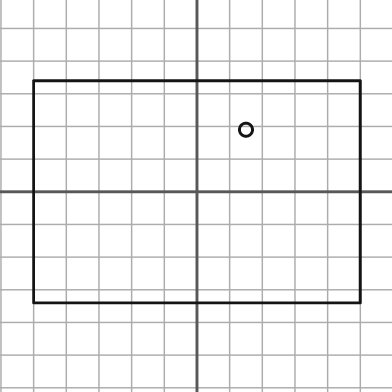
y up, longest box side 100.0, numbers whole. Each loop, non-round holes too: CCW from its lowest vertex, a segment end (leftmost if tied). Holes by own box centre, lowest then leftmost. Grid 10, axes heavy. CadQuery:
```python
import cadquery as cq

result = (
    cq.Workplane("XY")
    .moveTo(-50.0, -34.0)
    .lineTo(50.0, -34.0)
    .lineTo(50.0, 34.0)
    .lineTo(-50.0, 34.0)
    .close()
    .moveTo(15.0, 19.0)
    .circle(2.0)
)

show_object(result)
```